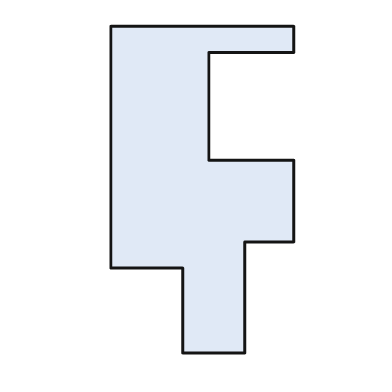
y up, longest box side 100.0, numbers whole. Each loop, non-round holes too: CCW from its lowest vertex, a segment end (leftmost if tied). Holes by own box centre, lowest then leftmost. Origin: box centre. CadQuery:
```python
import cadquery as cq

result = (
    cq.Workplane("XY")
    .moveTo(-6.0, -50.0)
    .lineTo(13.0, -50.0)
    .lineTo(13.0, -16.0)
    .lineTo(28.0, -16.0)
    .lineTo(28.0, 9.0)
    .lineTo(2.0, 9.0)
    .lineTo(2.0, 42.0)
    .lineTo(28.0, 42.0)
    .lineTo(28.0, 50.0)
    .lineTo(-28.0, 50.0)
    .lineTo(-28.0, -24.0)
    .lineTo(-6.0, -24.0)
    .close()
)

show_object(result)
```